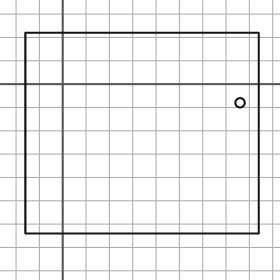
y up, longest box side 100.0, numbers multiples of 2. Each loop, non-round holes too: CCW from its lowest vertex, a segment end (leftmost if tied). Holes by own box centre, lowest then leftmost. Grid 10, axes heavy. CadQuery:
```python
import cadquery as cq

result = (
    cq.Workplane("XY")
    .moveTo(-16.0, -64.0)
    .lineTo(84.0, -64.0)
    .lineTo(84.0, 22.0)
    .lineTo(-16.0, 22.0)
    .close()
    .moveTo(76.0, -8.0)
    .circle(2.0)
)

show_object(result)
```